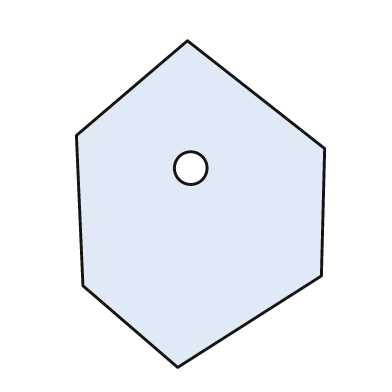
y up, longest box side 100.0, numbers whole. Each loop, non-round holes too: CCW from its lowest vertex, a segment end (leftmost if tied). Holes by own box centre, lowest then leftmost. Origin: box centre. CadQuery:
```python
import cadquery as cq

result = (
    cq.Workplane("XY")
    .moveTo(-7.0, -50.0)
    .lineTo(37.0, -22.0)
    .lineTo(38.0, 17.0)
    .lineTo(-4.0, 50.0)
    .lineTo(-38.0, 21.0)
    .lineTo(-36.0, -25.0)
    .close()
    .moveTo(-3.0, 11.0)
    .circle(5.0)
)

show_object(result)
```